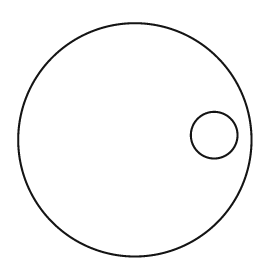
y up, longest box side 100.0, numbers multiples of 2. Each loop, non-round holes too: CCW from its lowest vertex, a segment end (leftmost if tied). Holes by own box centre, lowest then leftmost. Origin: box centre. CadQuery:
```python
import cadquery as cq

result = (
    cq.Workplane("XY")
    .moveTo(0.0, 0.0)
    .circle(50.0)
    .moveTo(34.0, 2.0)
    .circle(10.0)
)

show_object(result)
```